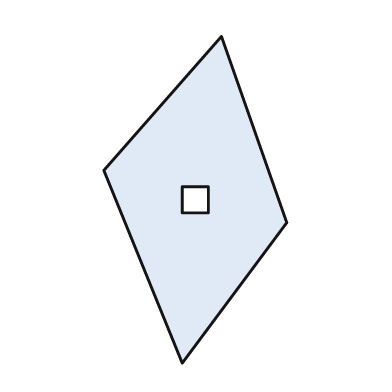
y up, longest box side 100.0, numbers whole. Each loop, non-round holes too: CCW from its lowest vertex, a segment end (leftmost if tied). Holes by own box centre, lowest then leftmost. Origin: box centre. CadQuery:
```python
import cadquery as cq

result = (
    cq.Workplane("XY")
    .moveTo(-4.0, -50.0)
    .lineTo(28.0, -7.0)
    .lineTo(8.0, 50.0)
    .lineTo(-28.0, 9.0)
    .close()
    .moveTo(-4.0, -4.0)
    .lineTo(4.0, -4.0)
    .lineTo(4.0, 4.0)
    .lineTo(-4.0, 4.0)
    .close()
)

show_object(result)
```